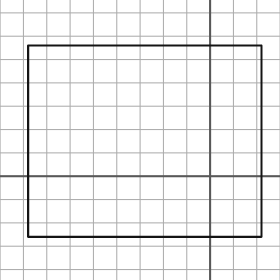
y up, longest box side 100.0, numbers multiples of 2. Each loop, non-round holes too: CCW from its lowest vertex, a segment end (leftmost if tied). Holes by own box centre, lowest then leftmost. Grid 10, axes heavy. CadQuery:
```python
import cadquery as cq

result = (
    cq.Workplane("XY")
    .moveTo(-78.0, -26.0)
    .lineTo(22.0, -26.0)
    .lineTo(22.0, 56.0)
    .lineTo(-78.0, 56.0)
    .close()
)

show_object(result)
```